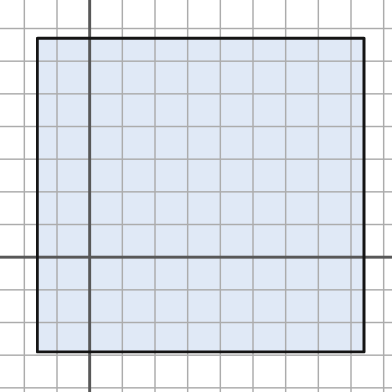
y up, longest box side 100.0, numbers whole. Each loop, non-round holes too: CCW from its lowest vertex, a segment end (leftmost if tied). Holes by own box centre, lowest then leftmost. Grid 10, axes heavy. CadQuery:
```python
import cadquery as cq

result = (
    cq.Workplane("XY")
    .moveTo(-16.0, -29.0)
    .lineTo(84.0, -29.0)
    .lineTo(84.0, 67.0)
    .lineTo(-16.0, 67.0)
    .close()
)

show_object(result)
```